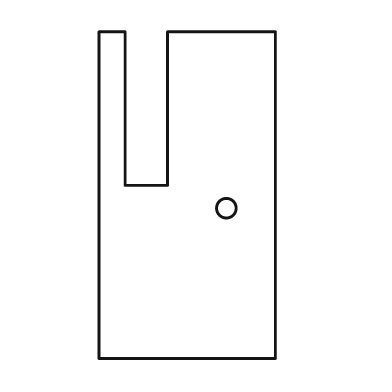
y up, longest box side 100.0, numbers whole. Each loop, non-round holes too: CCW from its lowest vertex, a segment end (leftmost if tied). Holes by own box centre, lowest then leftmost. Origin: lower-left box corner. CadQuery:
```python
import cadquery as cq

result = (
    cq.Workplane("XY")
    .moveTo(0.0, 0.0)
    .lineTo(54.0, 0.0)
    .lineTo(54.0, 100.0)
    .lineTo(21.0, 100.0)
    .lineTo(21.0, 53.0)
    .lineTo(8.0, 53.0)
    .lineTo(8.0, 100.0)
    .lineTo(0.0, 100.0)
    .close()
    .moveTo(39.0, 46.0)
    .circle(3.0)
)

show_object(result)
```